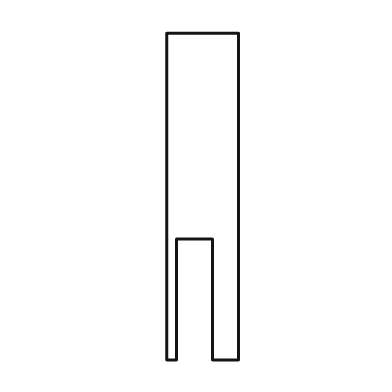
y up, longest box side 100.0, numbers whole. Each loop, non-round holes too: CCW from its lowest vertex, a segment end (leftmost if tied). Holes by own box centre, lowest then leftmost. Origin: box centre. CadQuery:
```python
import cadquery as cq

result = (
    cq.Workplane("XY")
    .moveTo(-11.0, -50.0)
    .lineTo(-8.0, -50.0)
    .lineTo(-8.0, -13.0)
    .lineTo(3.0, -13.0)
    .lineTo(3.0, -50.0)
    .lineTo(11.0, -50.0)
    .lineTo(11.0, 50.0)
    .lineTo(-11.0, 50.0)
    .close()
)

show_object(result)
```